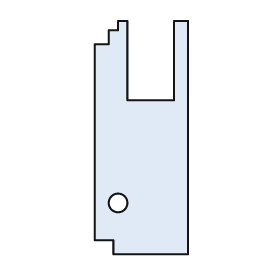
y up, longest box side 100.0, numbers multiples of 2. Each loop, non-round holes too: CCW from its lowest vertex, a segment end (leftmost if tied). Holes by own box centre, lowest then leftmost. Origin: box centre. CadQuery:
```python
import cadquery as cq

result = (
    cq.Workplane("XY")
    .moveTo(-12.0, -50.0)
    .lineTo(20.0, -50.0)
    .lineTo(20.0, 50.0)
    .lineTo(14.0, 50.0)
    .lineTo(14.0, 16.0)
    .lineTo(-6.0, 16.0)
    .lineTo(-6.0, 50.0)
    .lineTo(-10.0, 50.0)
    .lineTo(-10.0, 46.0)
    .lineTo(-14.0, 46.0)
    .lineTo(-14.0, 40.0)
    .lineTo(-20.0, 40.0)
    .lineTo(-20.0, -44.0)
    .lineTo(-12.0, -44.0)
    .close()
    .moveTo(-10.0, -28.0)
    .circle(4.0)
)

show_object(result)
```